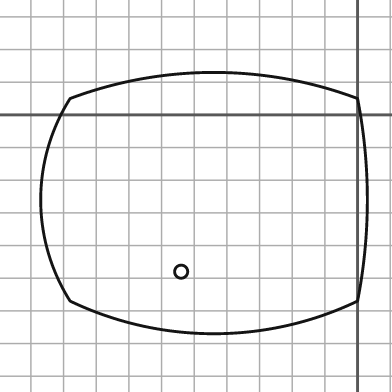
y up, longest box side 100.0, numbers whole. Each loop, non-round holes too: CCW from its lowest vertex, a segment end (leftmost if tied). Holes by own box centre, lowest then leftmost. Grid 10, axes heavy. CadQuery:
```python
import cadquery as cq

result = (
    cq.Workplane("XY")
    .moveTo(-88.0, -57.0)
    .threePointArc((-44.0, -67.0), (0.0, -57.0))
    .threePointArc((3.0, -26.0), (0.0, 5.0))
    .threePointArc((-44.0, 13.0), (-88.0, 5.0))
    .threePointArc((-97.0, -26.0), (-88.0, -57.0))
    .close()
    .moveTo(-54.0, -48.0)
    .circle(2.0)
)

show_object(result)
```